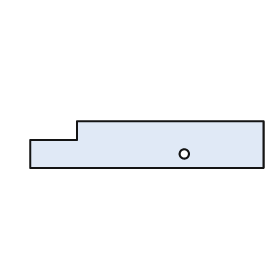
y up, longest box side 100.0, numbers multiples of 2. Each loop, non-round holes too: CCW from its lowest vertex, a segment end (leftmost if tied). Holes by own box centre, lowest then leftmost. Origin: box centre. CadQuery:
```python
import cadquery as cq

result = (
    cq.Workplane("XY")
    .moveTo(-50.0, -10.0)
    .lineTo(50.0, -10.0)
    .lineTo(50.0, 10.0)
    .lineTo(-30.0, 10.0)
    .lineTo(-30.0, 2.0)
    .lineTo(-50.0, 2.0)
    .close()
    .moveTo(16.0, -4.0)
    .circle(2.0)
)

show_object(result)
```